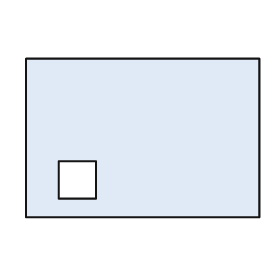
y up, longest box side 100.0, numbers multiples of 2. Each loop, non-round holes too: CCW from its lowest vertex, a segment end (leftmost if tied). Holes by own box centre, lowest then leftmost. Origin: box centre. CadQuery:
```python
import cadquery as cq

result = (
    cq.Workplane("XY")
    .moveTo(-50.0, -34.0)
    .lineTo(50.0, -34.0)
    .lineTo(50.0, 34.0)
    .lineTo(-50.0, 34.0)
    .close()
    .moveTo(-36.0, -26.0)
    .lineTo(-20.0, -26.0)
    .lineTo(-20.0, -10.0)
    .lineTo(-36.0, -10.0)
    .close()
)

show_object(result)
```